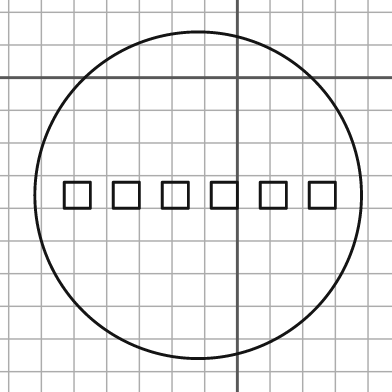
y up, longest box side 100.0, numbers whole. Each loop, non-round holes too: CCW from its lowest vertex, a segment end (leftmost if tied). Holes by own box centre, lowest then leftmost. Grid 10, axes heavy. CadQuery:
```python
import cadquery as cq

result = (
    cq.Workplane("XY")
    .moveTo(-12.0, -36.0)
    .circle(50.0)
    .moveTo(-53.0, -40.0)
    .lineTo(-45.0, -40.0)
    .lineTo(-45.0, -32.0)
    .lineTo(-53.0, -32.0)
    .close()
    .moveTo(-38.0, -40.0)
    .lineTo(-30.0, -40.0)
    .lineTo(-30.0, -32.0)
    .lineTo(-38.0, -32.0)
    .close()
    .moveTo(-23.0, -40.0)
    .lineTo(-15.0, -40.0)
    .lineTo(-15.0, -32.0)
    .lineTo(-23.0, -32.0)
    .close()
    .moveTo(-8.0, -40.0)
    .lineTo(0.0, -40.0)
    .lineTo(0.0, -32.0)
    .lineTo(-8.0, -32.0)
    .close()
    .moveTo(7.0, -40.0)
    .lineTo(15.0, -40.0)
    .lineTo(15.0, -32.0)
    .lineTo(7.0, -32.0)
    .close()
    .moveTo(22.0, -40.0)
    .lineTo(30.0, -40.0)
    .lineTo(30.0, -32.0)
    .lineTo(22.0, -32.0)
    .close()
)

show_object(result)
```